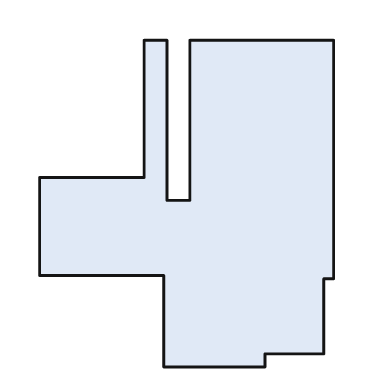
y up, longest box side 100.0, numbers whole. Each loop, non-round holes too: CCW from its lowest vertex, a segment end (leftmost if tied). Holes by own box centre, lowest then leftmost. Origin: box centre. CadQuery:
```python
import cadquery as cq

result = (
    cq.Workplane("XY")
    .moveTo(-7.0, -50.0)
    .lineTo(24.0, -50.0)
    .lineTo(24.0, -46.0)
    .lineTo(42.0, -46.0)
    .lineTo(42.0, -23.0)
    .lineTo(45.0, -23.0)
    .lineTo(45.0, 50.0)
    .lineTo(1.0, 50.0)
    .lineTo(1.0, 1.0)
    .lineTo(-6.0, 1.0)
    .lineTo(-6.0, 50.0)
    .lineTo(-13.0, 50.0)
    .lineTo(-13.0, 8.0)
    .lineTo(-45.0, 8.0)
    .lineTo(-45.0, -22.0)
    .lineTo(-7.0, -22.0)
    .close()
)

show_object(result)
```